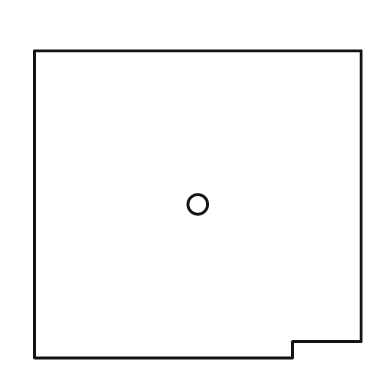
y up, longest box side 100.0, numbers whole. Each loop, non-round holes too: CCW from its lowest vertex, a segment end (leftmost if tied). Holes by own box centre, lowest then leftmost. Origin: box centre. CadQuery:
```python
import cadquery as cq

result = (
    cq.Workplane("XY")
    .moveTo(-50.0, -47.0)
    .lineTo(29.0, -47.0)
    .lineTo(29.0, -42.0)
    .lineTo(50.0, -42.0)
    .lineTo(50.0, 47.0)
    .lineTo(-50.0, 47.0)
    .close()
    .moveTo(0.0, 0.0)
    .circle(3.0)
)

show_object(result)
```